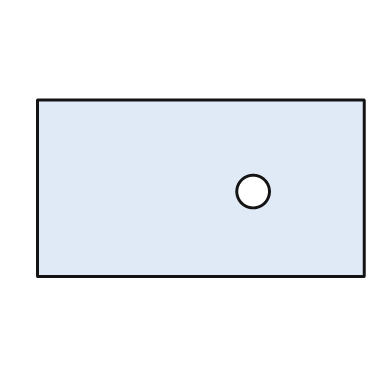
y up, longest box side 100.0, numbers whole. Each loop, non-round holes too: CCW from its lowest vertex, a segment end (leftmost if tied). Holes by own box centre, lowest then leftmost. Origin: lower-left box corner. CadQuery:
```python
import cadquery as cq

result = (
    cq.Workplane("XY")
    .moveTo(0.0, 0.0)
    .lineTo(100.0, 0.0)
    .lineTo(100.0, 54.0)
    .lineTo(0.0, 54.0)
    .close()
    .moveTo(66.0, 26.0)
    .circle(5.0)
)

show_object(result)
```